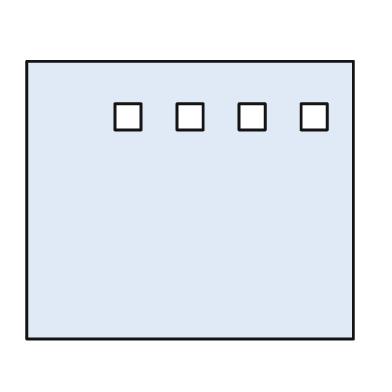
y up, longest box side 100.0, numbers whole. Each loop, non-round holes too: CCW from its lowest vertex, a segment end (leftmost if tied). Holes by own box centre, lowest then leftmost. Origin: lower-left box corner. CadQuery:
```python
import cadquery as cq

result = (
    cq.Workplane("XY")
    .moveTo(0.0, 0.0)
    .lineTo(100.0, 0.0)
    .lineTo(100.0, 85.0)
    .lineTo(0.0, 85.0)
    .close()
    .moveTo(27.0, 64.0)
    .lineTo(35.0, 64.0)
    .lineTo(35.0, 72.0)
    .lineTo(27.0, 72.0)
    .close()
    .moveTo(46.0, 64.0)
    .lineTo(54.0, 64.0)
    .lineTo(54.0, 72.0)
    .lineTo(46.0, 72.0)
    .close()
    .moveTo(65.0, 64.0)
    .lineTo(73.0, 64.0)
    .lineTo(73.0, 72.0)
    .lineTo(65.0, 72.0)
    .close()
    .moveTo(84.0, 64.0)
    .lineTo(92.0, 64.0)
    .lineTo(92.0, 72.0)
    .lineTo(84.0, 72.0)
    .close()
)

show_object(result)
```